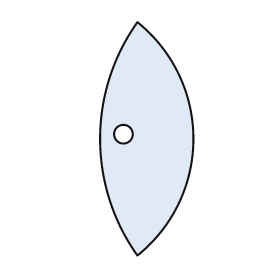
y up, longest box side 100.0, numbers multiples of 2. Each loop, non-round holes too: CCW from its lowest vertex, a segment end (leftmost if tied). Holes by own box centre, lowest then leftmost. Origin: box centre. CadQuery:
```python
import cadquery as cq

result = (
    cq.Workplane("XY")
    .moveTo(-4.0, -50.0)
    .threePointArc((20.0, 0.0), (-4.0, 50.0))
    .threePointArc((-20.0, 0.0), (-4.0, -50.0))
    .close()
    .moveTo(-10.0, 2.0)
    .circle(4.0)
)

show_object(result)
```